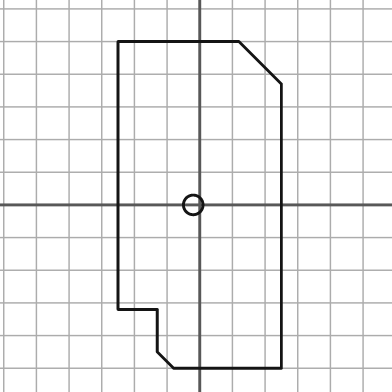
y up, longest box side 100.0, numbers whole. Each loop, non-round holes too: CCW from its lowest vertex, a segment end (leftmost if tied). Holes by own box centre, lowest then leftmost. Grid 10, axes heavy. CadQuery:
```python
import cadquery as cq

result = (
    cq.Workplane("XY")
    .moveTo(-8.0, -50.0)
    .lineTo(25.0, -50.0)
    .lineTo(25.0, 37.0)
    .lineTo(12.0, 50.0)
    .lineTo(-25.0, 50.0)
    .lineTo(-25.0, -32.0)
    .lineTo(-13.0, -32.0)
    .lineTo(-13.0, -45.0)
    .close()
    .moveTo(-2.0, 0.0)
    .circle(3.0)
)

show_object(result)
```